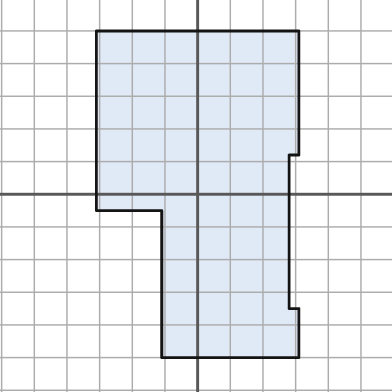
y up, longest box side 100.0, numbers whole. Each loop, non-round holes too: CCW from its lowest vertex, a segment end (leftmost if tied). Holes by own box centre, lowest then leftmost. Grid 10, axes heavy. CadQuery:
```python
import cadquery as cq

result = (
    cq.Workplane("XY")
    .moveTo(-11.0, -50.0)
    .lineTo(31.0, -50.0)
    .lineTo(31.0, -35.0)
    .lineTo(28.0, -35.0)
    .lineTo(28.0, 12.0)
    .lineTo(31.0, 12.0)
    .lineTo(31.0, 50.0)
    .lineTo(-31.0, 50.0)
    .lineTo(-31.0, -5.0)
    .lineTo(-11.0, -5.0)
    .close()
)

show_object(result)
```